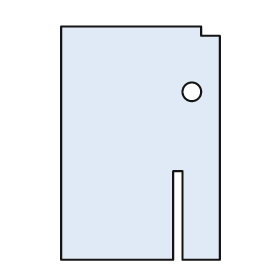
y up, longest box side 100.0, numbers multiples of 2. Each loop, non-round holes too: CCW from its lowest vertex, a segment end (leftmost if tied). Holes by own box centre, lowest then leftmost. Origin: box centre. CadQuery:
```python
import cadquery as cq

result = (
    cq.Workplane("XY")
    .moveTo(-34.0, -50.0)
    .lineTo(14.0, -50.0)
    .lineTo(14.0, -12.0)
    .lineTo(18.0, -12.0)
    .lineTo(18.0, -50.0)
    .lineTo(34.0, -50.0)
    .lineTo(34.0, 46.0)
    .lineTo(26.0, 46.0)
    .lineTo(26.0, 50.0)
    .lineTo(-34.0, 50.0)
    .close()
    .moveTo(22.0, 22.0)
    .circle(4.0)
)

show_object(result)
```